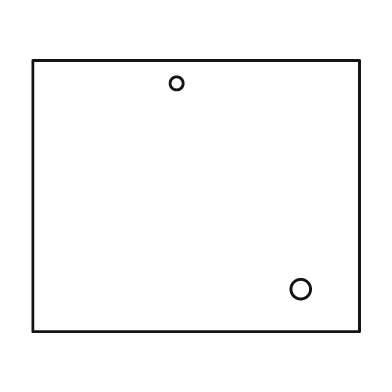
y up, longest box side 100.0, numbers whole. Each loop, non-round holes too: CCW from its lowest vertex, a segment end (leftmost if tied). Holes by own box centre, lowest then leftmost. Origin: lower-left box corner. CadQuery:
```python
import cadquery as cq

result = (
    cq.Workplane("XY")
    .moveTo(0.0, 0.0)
    .lineTo(100.0, 0.0)
    .lineTo(100.0, 83.0)
    .lineTo(0.0, 83.0)
    .close()
    .moveTo(82.0, 13.0)
    .circle(3.0)
    .moveTo(44.0, 76.0)
    .circle(2.0)
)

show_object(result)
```